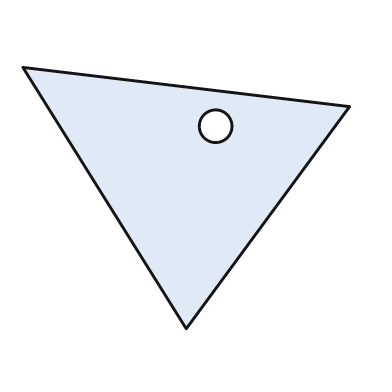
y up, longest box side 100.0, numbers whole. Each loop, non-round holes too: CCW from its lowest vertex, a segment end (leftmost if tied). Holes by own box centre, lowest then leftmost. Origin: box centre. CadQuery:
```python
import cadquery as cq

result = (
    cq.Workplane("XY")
    .moveTo(0.0, -40.0)
    .lineTo(50.0, 28.0)
    .lineTo(-50.0, 40.0)
    .close()
    .moveTo(9.0, 22.0)
    .circle(5.0)
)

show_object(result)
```